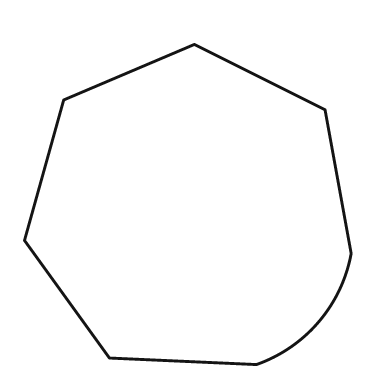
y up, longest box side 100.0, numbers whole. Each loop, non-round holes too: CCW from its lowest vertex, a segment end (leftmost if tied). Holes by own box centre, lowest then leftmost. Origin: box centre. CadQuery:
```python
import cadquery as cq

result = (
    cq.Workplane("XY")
    .moveTo(21.0, -49.0)
    .threePointArc((40.0, -36.0), (50.0, -15.0))
    .lineTo(42.0, 29.0)
    .lineTo(2.0, 49.0)
    .lineTo(-38.0, 32.0)
    .lineTo(-50.0, -11.0)
    .lineTo(-24.0, -47.0)
    .close()
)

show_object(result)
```